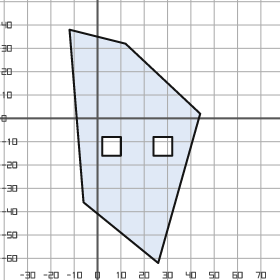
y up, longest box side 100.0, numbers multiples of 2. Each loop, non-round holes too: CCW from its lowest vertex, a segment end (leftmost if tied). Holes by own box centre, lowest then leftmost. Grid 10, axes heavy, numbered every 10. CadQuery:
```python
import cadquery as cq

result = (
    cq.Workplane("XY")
    .moveTo(26.0, -62.0)
    .lineTo(44.0, 2.0)
    .lineTo(12.0, 32.0)
    .lineTo(-12.0, 38.0)
    .lineTo(-6.0, -36.0)
    .close()
    .moveTo(2.0, -16.0)
    .lineTo(10.0, -16.0)
    .lineTo(10.0, -8.0)
    .lineTo(2.0, -8.0)
    .close()
    .moveTo(24.0, -16.0)
    .lineTo(32.0, -16.0)
    .lineTo(32.0, -8.0)
    .lineTo(24.0, -8.0)
    .close()
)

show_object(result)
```